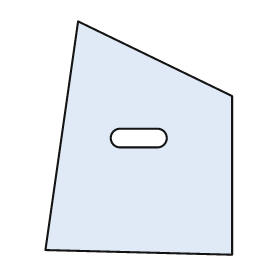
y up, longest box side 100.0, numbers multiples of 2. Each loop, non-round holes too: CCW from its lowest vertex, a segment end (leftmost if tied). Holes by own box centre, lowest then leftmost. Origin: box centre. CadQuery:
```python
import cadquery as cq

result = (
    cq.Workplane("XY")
    .moveTo(40.0, -50.0)
    .lineTo(40.0, 18.0)
    .lineTo(-26.0, 50.0)
    .lineTo(-40.0, -48.0)
    .close()
    .moveTo(-8.0, -4.0)
    .lineTo(8.0, -4.0)
    .threePointArc((12.0, 0.0), (8.0, 4.0))
    .lineTo(-8.0, 4.0)
    .threePointArc((-12.0, 0.0), (-8.0, -4.0))
    .close()
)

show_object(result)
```